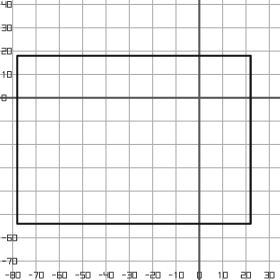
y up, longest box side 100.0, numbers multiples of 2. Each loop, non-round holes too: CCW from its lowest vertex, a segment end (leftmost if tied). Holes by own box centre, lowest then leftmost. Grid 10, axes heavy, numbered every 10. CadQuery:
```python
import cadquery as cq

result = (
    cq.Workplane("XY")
    .moveTo(-78.0, -54.0)
    .lineTo(22.0, -54.0)
    .lineTo(22.0, 18.0)
    .lineTo(-78.0, 18.0)
    .close()
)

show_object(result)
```